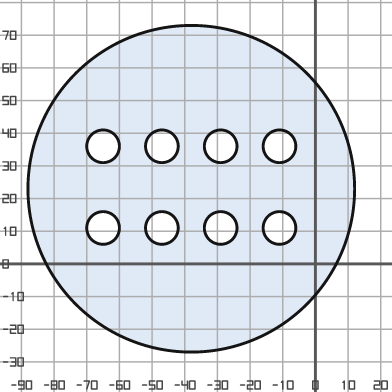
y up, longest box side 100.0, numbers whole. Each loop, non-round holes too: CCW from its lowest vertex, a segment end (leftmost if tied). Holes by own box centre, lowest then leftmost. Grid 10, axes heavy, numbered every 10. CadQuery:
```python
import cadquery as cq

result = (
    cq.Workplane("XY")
    .moveTo(-38.0, 23.0)
    .circle(50.0)
    .moveTo(-65.0, 11.0)
    .circle(5.0)
    .moveTo(-47.0, 11.0)
    .circle(5.0)
    .moveTo(-29.0, 11.0)
    .circle(5.0)
    .moveTo(-11.0, 11.0)
    .circle(5.0)
    .moveTo(-65.0, 36.0)
    .circle(5.0)
    .moveTo(-47.0, 36.0)
    .circle(5.0)
    .moveTo(-29.0, 36.0)
    .circle(5.0)
    .moveTo(-11.0, 36.0)
    .circle(5.0)
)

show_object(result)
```